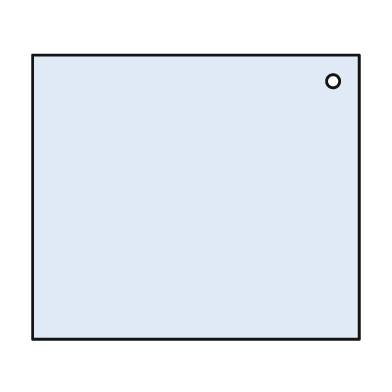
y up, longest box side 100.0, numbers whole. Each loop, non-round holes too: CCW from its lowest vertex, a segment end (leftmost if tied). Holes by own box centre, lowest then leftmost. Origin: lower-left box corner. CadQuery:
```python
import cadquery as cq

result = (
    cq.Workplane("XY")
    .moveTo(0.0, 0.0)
    .lineTo(100.0, 0.0)
    .lineTo(100.0, 87.0)
    .lineTo(0.0, 87.0)
    .close()
    .moveTo(92.0, 79.0)
    .circle(2.0)
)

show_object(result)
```